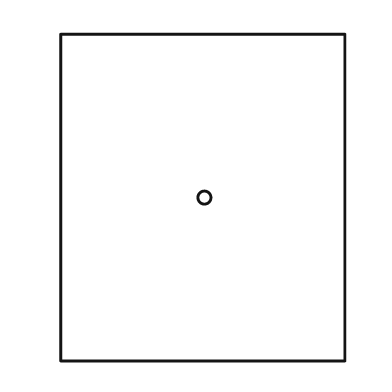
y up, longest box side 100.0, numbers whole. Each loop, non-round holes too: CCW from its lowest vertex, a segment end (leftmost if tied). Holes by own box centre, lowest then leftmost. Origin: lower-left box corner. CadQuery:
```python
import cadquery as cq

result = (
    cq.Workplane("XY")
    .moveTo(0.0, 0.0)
    .lineTo(87.0, 0.0)
    .lineTo(87.0, 100.0)
    .lineTo(0.0, 100.0)
    .close()
    .moveTo(44.0, 50.0)
    .circle(2.0)
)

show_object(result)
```